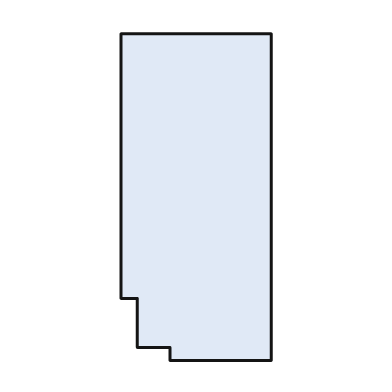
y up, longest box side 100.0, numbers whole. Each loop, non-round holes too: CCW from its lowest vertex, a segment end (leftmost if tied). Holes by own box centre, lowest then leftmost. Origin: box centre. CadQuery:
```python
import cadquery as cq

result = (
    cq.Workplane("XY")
    .moveTo(-8.0, -50.0)
    .lineTo(23.0, -50.0)
    .lineTo(23.0, 50.0)
    .lineTo(-23.0, 50.0)
    .lineTo(-23.0, -31.0)
    .lineTo(-18.0, -31.0)
    .lineTo(-18.0, -46.0)
    .lineTo(-8.0, -46.0)
    .close()
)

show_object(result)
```